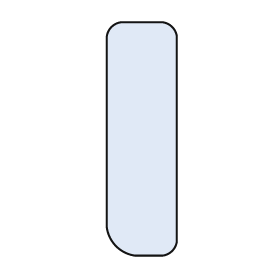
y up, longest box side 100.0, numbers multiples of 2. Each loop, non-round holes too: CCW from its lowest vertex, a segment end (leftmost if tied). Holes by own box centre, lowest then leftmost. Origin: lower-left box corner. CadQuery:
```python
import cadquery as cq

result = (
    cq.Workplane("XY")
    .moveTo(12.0, 0.0)
    .lineTo(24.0, 0.0)
    .threePointArc((28.0, 2.0), (30.0, 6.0))
    .lineTo(30.0, 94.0)
    .threePointArc((28.0, 98.0), (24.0, 100.0))
    .lineTo(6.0, 100.0)
    .threePointArc((2.0, 98.0), (0.0, 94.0))
    .lineTo(0.0, 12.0)
    .threePointArc((4.0, 4.0), (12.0, 0.0))
    .close()
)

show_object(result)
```